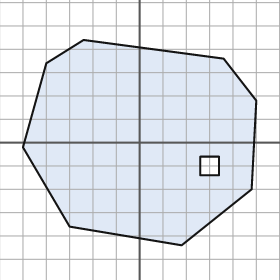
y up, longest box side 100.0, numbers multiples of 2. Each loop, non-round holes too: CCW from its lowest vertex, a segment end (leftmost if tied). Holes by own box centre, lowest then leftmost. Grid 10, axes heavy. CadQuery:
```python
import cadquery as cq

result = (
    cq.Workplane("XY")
    .moveTo(18.0, -44.0)
    .lineTo(48.0, -20.0)
    .lineTo(50.0, 18.0)
    .lineTo(36.0, 36.0)
    .lineTo(-24.0, 44.0)
    .lineTo(-40.0, 34.0)
    .lineTo(-50.0, -2.0)
    .lineTo(-30.0, -36.0)
    .close()
    .moveTo(26.0, -14.0)
    .lineTo(34.0, -14.0)
    .lineTo(34.0, -6.0)
    .lineTo(26.0, -6.0)
    .close()
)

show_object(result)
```